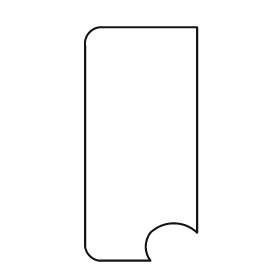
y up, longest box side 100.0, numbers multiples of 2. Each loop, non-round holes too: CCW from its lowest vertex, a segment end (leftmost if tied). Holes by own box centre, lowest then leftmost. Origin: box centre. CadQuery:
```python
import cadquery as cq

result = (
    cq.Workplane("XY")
    .moveTo(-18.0, -50.0)
    .lineTo(4.0, -50.0)
    .threePointArc((2.0, -44.0), (4.0, -38.0))
    .threePointArc((14.0, -34.0), (24.0, -38.0))
    .lineTo(24.0, 50.0)
    .lineTo(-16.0, 50.0)
    .threePointArc((-22.0, 48.0), (-24.0, 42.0))
    .lineTo(-24.0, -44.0)
    .threePointArc((-22.0, -48.0), (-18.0, -50.0))
    .close()
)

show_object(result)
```